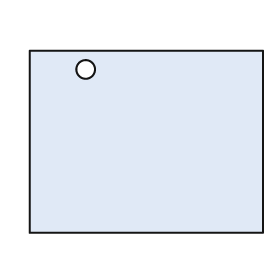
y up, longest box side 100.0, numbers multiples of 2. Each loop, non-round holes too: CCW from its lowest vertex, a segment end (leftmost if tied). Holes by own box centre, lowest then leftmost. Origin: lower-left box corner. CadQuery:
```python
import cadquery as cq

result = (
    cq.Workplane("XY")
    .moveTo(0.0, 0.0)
    .lineTo(100.0, 0.0)
    .lineTo(100.0, 78.0)
    .lineTo(0.0, 78.0)
    .close()
    .moveTo(24.0, 70.0)
    .circle(4.0)
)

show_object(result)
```